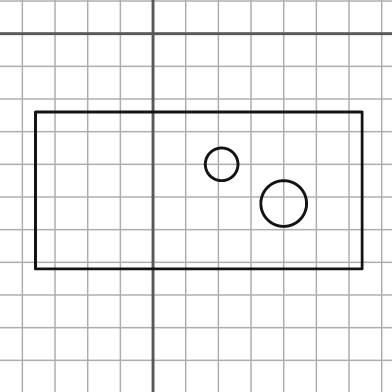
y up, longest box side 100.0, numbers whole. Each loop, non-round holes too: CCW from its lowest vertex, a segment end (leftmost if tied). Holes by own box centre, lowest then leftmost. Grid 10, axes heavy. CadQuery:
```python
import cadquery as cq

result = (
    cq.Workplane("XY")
    .moveTo(-36.0, -72.0)
    .lineTo(64.0, -72.0)
    .lineTo(64.0, -24.0)
    .lineTo(-36.0, -24.0)
    .close()
    .moveTo(40.0, -52.0)
    .circle(7.0)
    .moveTo(21.0, -40.0)
    .circle(5.0)
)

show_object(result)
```